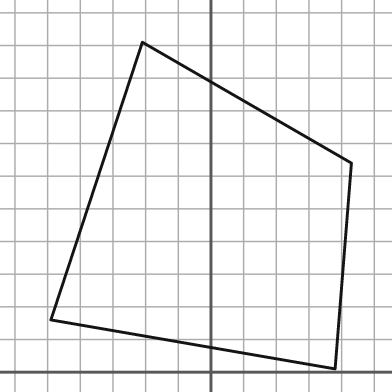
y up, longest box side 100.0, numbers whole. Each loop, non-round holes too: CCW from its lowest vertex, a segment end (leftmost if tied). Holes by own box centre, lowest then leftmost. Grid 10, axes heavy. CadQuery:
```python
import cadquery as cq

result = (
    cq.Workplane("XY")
    .moveTo(38.0, 1.0)
    .lineTo(43.0, 64.0)
    .lineTo(-21.0, 101.0)
    .lineTo(-49.0, 16.0)
    .close()
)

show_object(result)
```